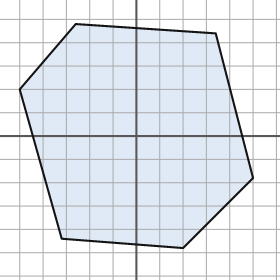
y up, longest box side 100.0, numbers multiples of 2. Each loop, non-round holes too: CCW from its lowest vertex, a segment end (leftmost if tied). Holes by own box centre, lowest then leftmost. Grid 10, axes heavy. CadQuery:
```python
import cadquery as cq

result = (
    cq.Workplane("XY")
    .moveTo(20.0, -48.0)
    .lineTo(50.0, -18.0)
    .lineTo(34.0, 44.0)
    .lineTo(-26.0, 48.0)
    .lineTo(-50.0, 20.0)
    .lineTo(-32.0, -44.0)
    .close()
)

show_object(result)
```